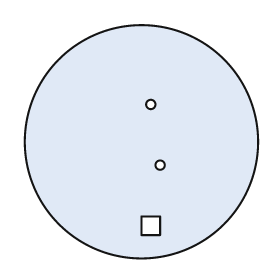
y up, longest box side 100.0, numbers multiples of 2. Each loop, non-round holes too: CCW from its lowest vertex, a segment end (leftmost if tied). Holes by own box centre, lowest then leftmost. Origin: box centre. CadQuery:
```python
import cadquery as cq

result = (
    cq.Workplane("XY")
    .moveTo(0.0, 0.0)
    .circle(50.0)
    .moveTo(0.0, -40.0)
    .lineTo(8.0, -40.0)
    .lineTo(8.0, -32.0)
    .lineTo(0.0, -32.0)
    .close()
    .moveTo(8.0, -10.0)
    .circle(2.0)
    .moveTo(4.0, 16.0)
    .circle(2.0)
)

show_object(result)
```